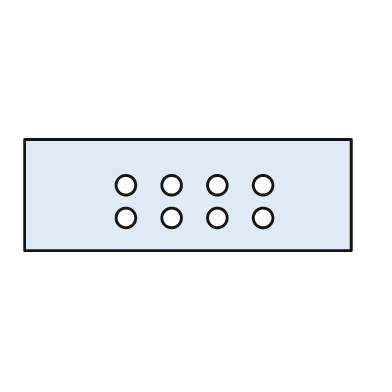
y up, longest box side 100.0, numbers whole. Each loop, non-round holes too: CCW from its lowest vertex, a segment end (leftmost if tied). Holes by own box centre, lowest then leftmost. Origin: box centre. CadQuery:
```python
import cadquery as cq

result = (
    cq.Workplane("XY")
    .moveTo(-50.0, -17.0)
    .lineTo(50.0, -17.0)
    .lineTo(50.0, 17.0)
    .lineTo(-50.0, 17.0)
    .close()
    .moveTo(-19.0, -7.0)
    .circle(3.0)
    .moveTo(-5.0, -7.0)
    .circle(3.0)
    .moveTo(9.0, -7.0)
    .circle(3.0)
    .moveTo(23.0, -7.0)
    .circle(3.0)
    .moveTo(-19.0, 3.0)
    .circle(3.0)
    .moveTo(-5.0, 3.0)
    .circle(3.0)
    .moveTo(9.0, 3.0)
    .circle(3.0)
    .moveTo(23.0, 3.0)
    .circle(3.0)
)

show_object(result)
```